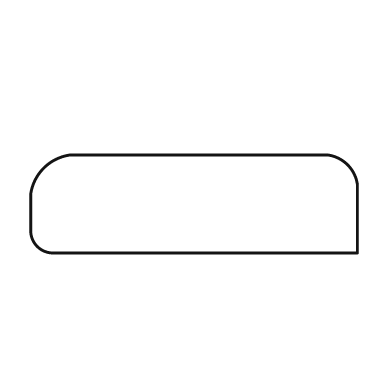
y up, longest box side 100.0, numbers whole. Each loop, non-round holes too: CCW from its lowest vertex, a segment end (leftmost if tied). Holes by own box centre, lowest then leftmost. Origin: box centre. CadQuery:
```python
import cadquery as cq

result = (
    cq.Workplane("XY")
    .moveTo(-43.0, -15.0)
    .lineTo(50.0, -15.0)
    .lineTo(50.0, 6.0)
    .threePointArc((47.0, 12.0), (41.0, 15.0))
    .lineTo(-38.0, 15.0)
    .threePointArc((-46.0, 11.0), (-50.0, 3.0))
    .lineTo(-50.0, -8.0)
    .threePointArc((-48.0, -13.0), (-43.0, -15.0))
    .close()
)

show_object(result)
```